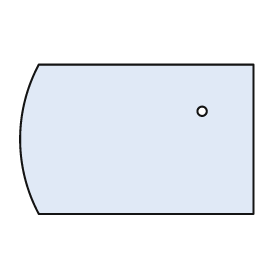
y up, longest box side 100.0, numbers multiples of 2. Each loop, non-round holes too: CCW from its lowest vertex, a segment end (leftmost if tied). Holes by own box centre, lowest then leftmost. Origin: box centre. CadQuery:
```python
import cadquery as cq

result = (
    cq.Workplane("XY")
    .moveTo(-42.0, -32.0)
    .lineTo(50.0, -32.0)
    .lineTo(50.0, 32.0)
    .lineTo(-42.0, 32.0)
    .threePointArc((-50.0, 0.0), (-42.0, -32.0))
    .close()
    .moveTo(28.0, 12.0)
    .circle(2.0)
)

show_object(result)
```